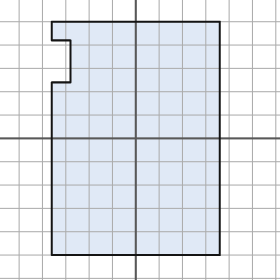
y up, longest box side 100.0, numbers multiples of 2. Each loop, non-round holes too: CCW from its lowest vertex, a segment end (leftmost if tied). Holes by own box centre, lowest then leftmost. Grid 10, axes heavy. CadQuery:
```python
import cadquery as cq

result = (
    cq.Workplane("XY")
    .moveTo(-36.0, -50.0)
    .lineTo(36.0, -50.0)
    .lineTo(36.0, 50.0)
    .lineTo(-36.0, 50.0)
    .lineTo(-36.0, 42.0)
    .lineTo(-28.0, 42.0)
    .lineTo(-28.0, 24.0)
    .lineTo(-36.0, 24.0)
    .close()
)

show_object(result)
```